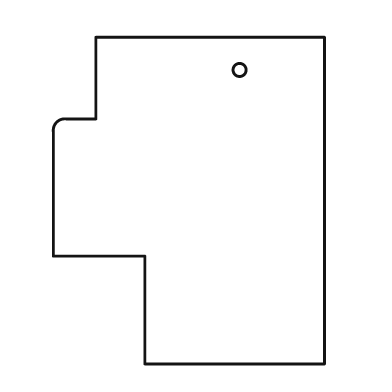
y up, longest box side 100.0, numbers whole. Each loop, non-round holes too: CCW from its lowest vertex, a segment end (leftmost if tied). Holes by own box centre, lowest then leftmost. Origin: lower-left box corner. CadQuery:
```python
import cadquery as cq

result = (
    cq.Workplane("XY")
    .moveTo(28.0, 0.0)
    .lineTo(83.0, 0.0)
    .lineTo(83.0, 100.0)
    .lineTo(13.0, 100.0)
    .lineTo(13.0, 75.0)
    .lineTo(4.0, 75.0)
    .threePointArc((1.0, 74.0), (0.0, 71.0))
    .lineTo(0.0, 33.0)
    .lineTo(28.0, 33.0)
    .close()
    .moveTo(57.0, 90.0)
    .circle(2.0)
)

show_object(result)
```